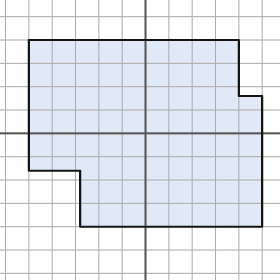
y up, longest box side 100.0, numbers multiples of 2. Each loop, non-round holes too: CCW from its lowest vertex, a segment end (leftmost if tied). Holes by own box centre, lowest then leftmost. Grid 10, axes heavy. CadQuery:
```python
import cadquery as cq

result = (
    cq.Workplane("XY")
    .moveTo(-28.0, -40.0)
    .lineTo(50.0, -40.0)
    .lineTo(50.0, 16.0)
    .lineTo(40.0, 16.0)
    .lineTo(40.0, 40.0)
    .lineTo(-50.0, 40.0)
    .lineTo(-50.0, -16.0)
    .lineTo(-28.0, -16.0)
    .close()
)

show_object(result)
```